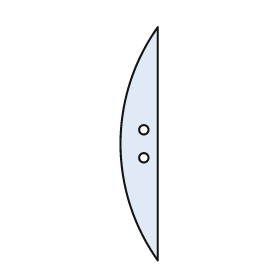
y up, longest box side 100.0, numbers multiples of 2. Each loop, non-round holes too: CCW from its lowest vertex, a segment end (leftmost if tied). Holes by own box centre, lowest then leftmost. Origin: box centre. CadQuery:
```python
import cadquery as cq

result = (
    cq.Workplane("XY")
    .moveTo(8.0, -50.0)
    .lineTo(8.0, 50.0)
    .threePointArc((-8.0, 0.0), (8.0, -50.0))
    .close()
    .moveTo(2.0, -6.0)
    .circle(2.0)
    .moveTo(2.0, 6.0)
    .circle(2.0)
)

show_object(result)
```